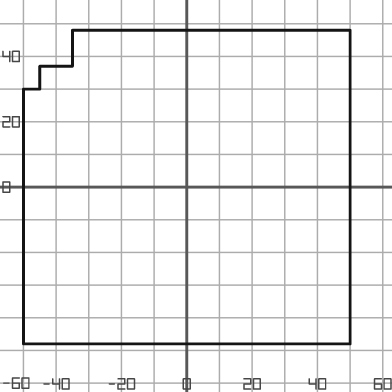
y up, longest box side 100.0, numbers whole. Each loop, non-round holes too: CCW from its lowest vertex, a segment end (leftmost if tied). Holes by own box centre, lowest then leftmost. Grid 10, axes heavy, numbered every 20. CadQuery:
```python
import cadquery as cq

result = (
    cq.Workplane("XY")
    .moveTo(-50.0, -48.0)
    .lineTo(50.0, -48.0)
    .lineTo(50.0, 48.0)
    .lineTo(-35.0, 48.0)
    .lineTo(-35.0, 37.0)
    .lineTo(-45.0, 37.0)
    .lineTo(-45.0, 30.0)
    .lineTo(-50.0, 30.0)
    .close()
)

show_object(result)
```